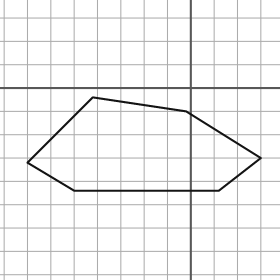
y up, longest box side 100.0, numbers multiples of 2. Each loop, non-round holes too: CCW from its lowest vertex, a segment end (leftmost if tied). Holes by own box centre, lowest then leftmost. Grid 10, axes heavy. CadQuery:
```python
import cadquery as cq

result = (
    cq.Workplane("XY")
    .moveTo(-50.0, -44.0)
    .lineTo(12.0, -44.0)
    .lineTo(30.0, -30.0)
    .lineTo(-2.0, -10.0)
    .lineTo(-42.0, -4.0)
    .lineTo(-70.0, -32.0)
    .close()
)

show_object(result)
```